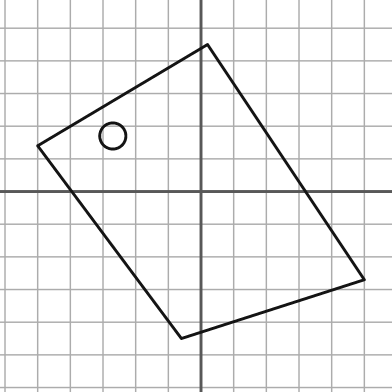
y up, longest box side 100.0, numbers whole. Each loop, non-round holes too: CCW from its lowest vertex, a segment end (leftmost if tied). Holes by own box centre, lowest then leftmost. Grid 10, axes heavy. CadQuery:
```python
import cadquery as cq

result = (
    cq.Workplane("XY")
    .moveTo(-6.0, -45.0)
    .lineTo(50.0, -27.0)
    .lineTo(2.0, 45.0)
    .lineTo(-50.0, 14.0)
    .close()
    .moveTo(-27.0, 17.0)
    .circle(4.0)
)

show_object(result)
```